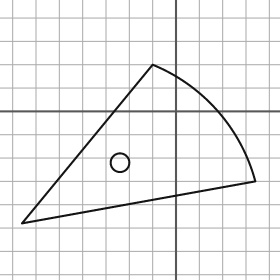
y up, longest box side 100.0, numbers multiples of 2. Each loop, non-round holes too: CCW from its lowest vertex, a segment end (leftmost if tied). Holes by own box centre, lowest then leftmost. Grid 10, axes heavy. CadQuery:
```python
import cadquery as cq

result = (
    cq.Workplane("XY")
    .moveTo(-66.0, -48.0)
    .lineTo(34.0, -30.0)
    .threePointArc((18.0, 0.0), (-10.0, 20.0))
    .close()
    .moveTo(-24.0, -22.0)
    .circle(4.0)
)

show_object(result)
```